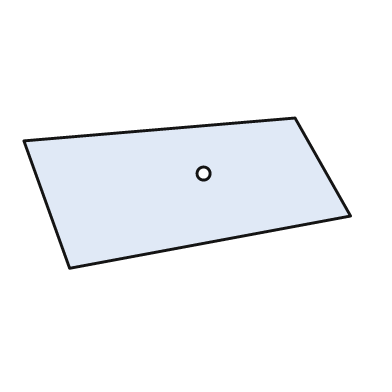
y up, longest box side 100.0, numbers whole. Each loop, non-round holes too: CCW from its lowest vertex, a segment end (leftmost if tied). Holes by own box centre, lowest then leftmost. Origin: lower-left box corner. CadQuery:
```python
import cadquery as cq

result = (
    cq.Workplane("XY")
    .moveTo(14.0, 0.0)
    .lineTo(100.0, 16.0)
    .lineTo(83.0, 46.0)
    .lineTo(0.0, 39.0)
    .close()
    .moveTo(55.0, 29.0)
    .circle(2.0)
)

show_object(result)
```